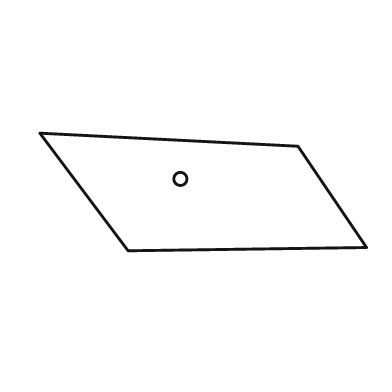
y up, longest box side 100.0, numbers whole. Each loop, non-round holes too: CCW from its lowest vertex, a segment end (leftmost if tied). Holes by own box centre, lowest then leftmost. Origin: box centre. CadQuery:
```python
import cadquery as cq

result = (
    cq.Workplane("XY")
    .moveTo(-23.0, -18.0)
    .lineTo(50.0, -17.0)
    .lineTo(29.0, 14.0)
    .lineTo(-50.0, 18.0)
    .close()
    .moveTo(-7.0, 4.0)
    .circle(2.0)
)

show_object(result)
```